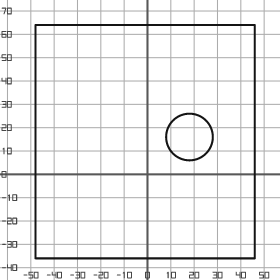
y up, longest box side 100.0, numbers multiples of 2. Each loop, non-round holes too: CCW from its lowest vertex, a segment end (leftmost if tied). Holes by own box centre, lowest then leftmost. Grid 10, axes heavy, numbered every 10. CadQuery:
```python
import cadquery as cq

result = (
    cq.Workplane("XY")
    .moveTo(-48.0, -36.0)
    .lineTo(46.0, -36.0)
    .lineTo(46.0, 64.0)
    .lineTo(-48.0, 64.0)
    .close()
    .moveTo(18.0, 16.0)
    .circle(10.0)
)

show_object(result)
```